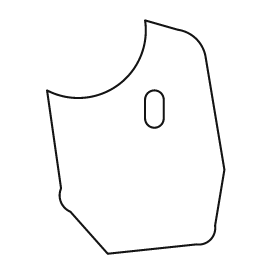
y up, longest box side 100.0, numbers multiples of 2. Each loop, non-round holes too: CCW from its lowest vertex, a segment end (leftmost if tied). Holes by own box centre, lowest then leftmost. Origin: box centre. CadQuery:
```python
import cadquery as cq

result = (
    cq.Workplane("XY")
    .moveTo(-12.0, -50.0)
    .lineTo(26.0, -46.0)
    .threePointArc((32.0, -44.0), (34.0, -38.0))
    .lineTo(38.0, -14.0)
    .lineTo(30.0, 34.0)
    .threePointArc((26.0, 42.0), (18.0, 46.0))
    .lineTo(4.0, 50.0)
    .threePointArc((-8.0, 22.0), (-38.0, 20.0))
    .lineTo(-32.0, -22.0)
    .threePointArc((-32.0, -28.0), (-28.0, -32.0))
    .close()
    .moveTo(4.0, 8.0)
    .threePointArc((8.0, 4.0), (12.0, 8.0))
    .lineTo(12.0, 16.0)
    .threePointArc((8.0, 20.0), (4.0, 16.0))
    .close()
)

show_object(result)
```